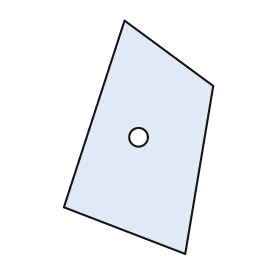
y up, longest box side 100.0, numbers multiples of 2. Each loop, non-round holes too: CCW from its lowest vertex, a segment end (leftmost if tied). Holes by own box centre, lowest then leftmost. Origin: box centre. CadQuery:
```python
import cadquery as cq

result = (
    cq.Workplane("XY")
    .moveTo(20.0, -50.0)
    .lineTo(32.0, 22.0)
    .lineTo(-6.0, 50.0)
    .lineTo(-32.0, -30.0)
    .close()
    .moveTo(0.0, 0.0)
    .circle(4.0)
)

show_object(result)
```